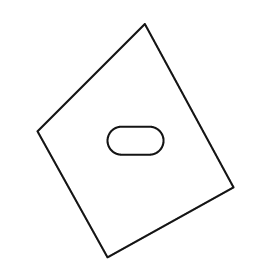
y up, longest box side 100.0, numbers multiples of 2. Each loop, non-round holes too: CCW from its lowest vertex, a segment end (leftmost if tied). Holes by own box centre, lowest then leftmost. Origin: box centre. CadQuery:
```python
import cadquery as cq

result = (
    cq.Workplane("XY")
    .moveTo(-12.0, -50.0)
    .lineTo(42.0, -20.0)
    .lineTo(4.0, 50.0)
    .lineTo(-42.0, 4.0)
    .close()
    .moveTo(-6.0, -6.0)
    .lineTo(6.0, -6.0)
    .threePointArc((12.0, 0.0), (6.0, 6.0))
    .lineTo(-6.0, 6.0)
    .threePointArc((-12.0, 0.0), (-6.0, -6.0))
    .close()
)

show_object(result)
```